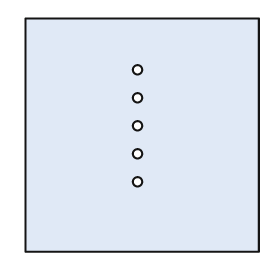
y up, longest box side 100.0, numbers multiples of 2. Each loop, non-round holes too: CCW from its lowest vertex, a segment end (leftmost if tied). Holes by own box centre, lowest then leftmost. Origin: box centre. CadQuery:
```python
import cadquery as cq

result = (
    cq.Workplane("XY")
    .moveTo(-50.0, -50.0)
    .lineTo(50.0, -50.0)
    .lineTo(50.0, 50.0)
    .lineTo(-50.0, 50.0)
    .close()
    .moveTo(-2.0, -20.0)
    .circle(2.0)
    .moveTo(-2.0, -8.0)
    .circle(2.0)
    .moveTo(-2.0, 4.0)
    .circle(2.0)
    .moveTo(-2.0, 16.0)
    .circle(2.0)
    .moveTo(-2.0, 28.0)
    .circle(2.0)
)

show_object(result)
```